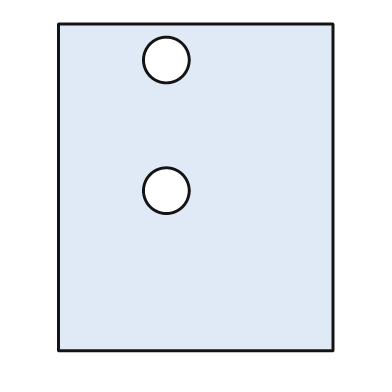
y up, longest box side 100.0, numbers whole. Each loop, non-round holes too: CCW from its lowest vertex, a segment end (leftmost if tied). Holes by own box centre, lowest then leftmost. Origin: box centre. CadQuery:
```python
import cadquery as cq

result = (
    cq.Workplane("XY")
    .moveTo(-42.0, -50.0)
    .lineTo(42.0, -50.0)
    .lineTo(42.0, 50.0)
    .lineTo(-42.0, 50.0)
    .close()
    .moveTo(-9.0, -1.0)
    .circle(7.0)
    .moveTo(-9.0, 39.0)
    .circle(7.0)
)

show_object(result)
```